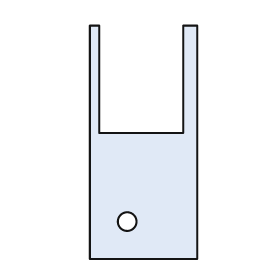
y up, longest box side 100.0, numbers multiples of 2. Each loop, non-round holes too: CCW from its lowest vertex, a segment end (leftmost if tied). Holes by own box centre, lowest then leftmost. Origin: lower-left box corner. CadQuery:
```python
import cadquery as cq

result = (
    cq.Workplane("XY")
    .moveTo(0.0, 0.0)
    .lineTo(46.0, 0.0)
    .lineTo(46.0, 100.0)
    .lineTo(40.0, 100.0)
    .lineTo(40.0, 54.0)
    .lineTo(4.0, 54.0)
    .lineTo(4.0, 100.0)
    .lineTo(0.0, 100.0)
    .close()
    .moveTo(16.0, 16.0)
    .circle(4.0)
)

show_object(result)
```